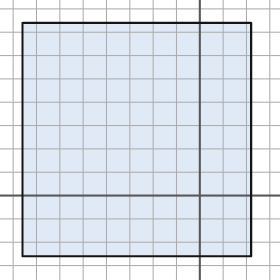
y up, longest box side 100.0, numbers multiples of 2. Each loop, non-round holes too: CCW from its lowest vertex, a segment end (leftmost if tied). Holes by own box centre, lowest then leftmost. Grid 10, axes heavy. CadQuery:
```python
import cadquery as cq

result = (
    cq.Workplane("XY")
    .moveTo(-76.0, -26.0)
    .lineTo(22.0, -26.0)
    .lineTo(22.0, 74.0)
    .lineTo(-76.0, 74.0)
    .close()
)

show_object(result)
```